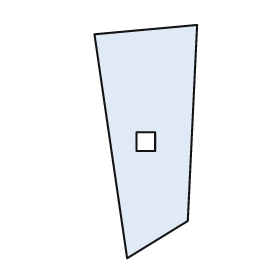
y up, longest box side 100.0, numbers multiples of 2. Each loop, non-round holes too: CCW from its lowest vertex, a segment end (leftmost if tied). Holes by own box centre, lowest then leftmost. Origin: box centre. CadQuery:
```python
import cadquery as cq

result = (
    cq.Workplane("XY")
    .moveTo(-8.0, -50.0)
    .lineTo(18.0, -34.0)
    .lineTo(22.0, 50.0)
    .lineTo(-22.0, 46.0)
    .close()
    .moveTo(-4.0, -4.0)
    .lineTo(4.0, -4.0)
    .lineTo(4.0, 4.0)
    .lineTo(-4.0, 4.0)
    .close()
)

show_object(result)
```